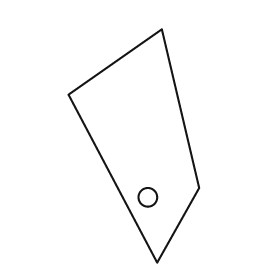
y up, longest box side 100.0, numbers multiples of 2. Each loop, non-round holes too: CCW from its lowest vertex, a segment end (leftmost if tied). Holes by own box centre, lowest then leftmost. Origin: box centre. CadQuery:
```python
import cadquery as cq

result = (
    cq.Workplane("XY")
    .moveTo(10.0, -50.0)
    .lineTo(28.0, -18.0)
    .lineTo(12.0, 50.0)
    .lineTo(-28.0, 22.0)
    .close()
    .moveTo(6.0, -22.0)
    .circle(4.0)
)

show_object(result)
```